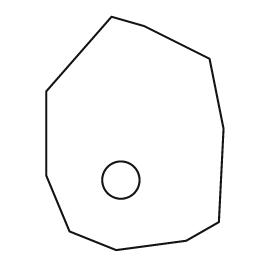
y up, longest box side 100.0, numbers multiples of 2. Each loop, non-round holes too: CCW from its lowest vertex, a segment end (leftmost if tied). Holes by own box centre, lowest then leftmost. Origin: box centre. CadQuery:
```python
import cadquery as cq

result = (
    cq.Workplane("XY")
    .moveTo(-8.0, -50.0)
    .lineTo(22.0, -46.0)
    .lineTo(36.0, -38.0)
    .lineTo(38.0, 2.0)
    .lineTo(32.0, 32.0)
    .lineTo(4.0, 46.0)
    .lineTo(-10.0, 50.0)
    .lineTo(-38.0, 18.0)
    .lineTo(-38.0, -18.0)
    .lineTo(-28.0, -42.0)
    .close()
    .moveTo(-6.0, -20.0)
    .circle(8.0)
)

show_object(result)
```